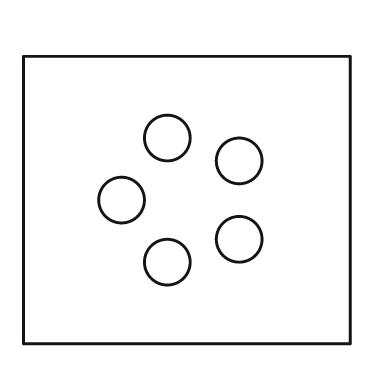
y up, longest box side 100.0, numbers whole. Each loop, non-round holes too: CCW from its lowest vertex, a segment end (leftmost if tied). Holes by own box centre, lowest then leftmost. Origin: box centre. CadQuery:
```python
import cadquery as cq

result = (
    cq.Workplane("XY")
    .moveTo(-50.0, -44.0)
    .lineTo(50.0, -44.0)
    .lineTo(50.0, 44.0)
    .lineTo(-50.0, 44.0)
    .close()
    .moveTo(-6.0, -19.0)
    .circle(7.0)
    .moveTo(16.0, -12.0)
    .circle(7.0)
    .moveTo(-20.0, 0.0)
    .circle(7.0)
    .moveTo(16.0, 12.0)
    .circle(7.0)
    .moveTo(-6.0, 19.0)
    .circle(7.0)
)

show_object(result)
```